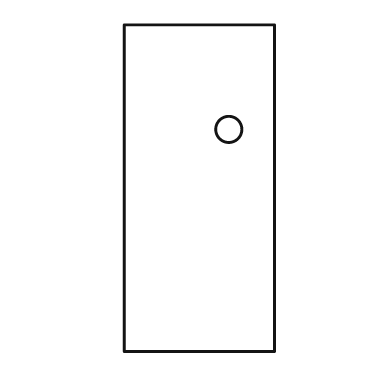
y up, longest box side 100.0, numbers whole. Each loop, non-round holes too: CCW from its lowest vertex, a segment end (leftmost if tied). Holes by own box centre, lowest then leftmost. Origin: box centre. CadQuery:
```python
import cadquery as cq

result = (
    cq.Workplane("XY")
    .moveTo(-23.0, -50.0)
    .lineTo(23.0, -50.0)
    .lineTo(23.0, 50.0)
    .lineTo(-23.0, 50.0)
    .close()
    .moveTo(9.0, 18.0)
    .circle(4.0)
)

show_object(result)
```